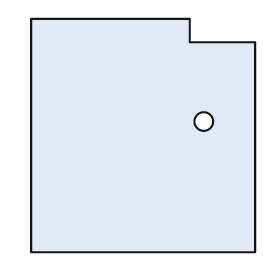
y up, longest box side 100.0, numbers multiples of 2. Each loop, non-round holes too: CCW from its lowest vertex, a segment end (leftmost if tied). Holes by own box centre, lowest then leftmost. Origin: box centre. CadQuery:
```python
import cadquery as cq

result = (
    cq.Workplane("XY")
    .moveTo(-48.0, -50.0)
    .lineTo(48.0, -50.0)
    .lineTo(48.0, 40.0)
    .lineTo(20.0, 40.0)
    .lineTo(20.0, 50.0)
    .lineTo(-48.0, 50.0)
    .close()
    .moveTo(26.0, 6.0)
    .circle(4.0)
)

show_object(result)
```